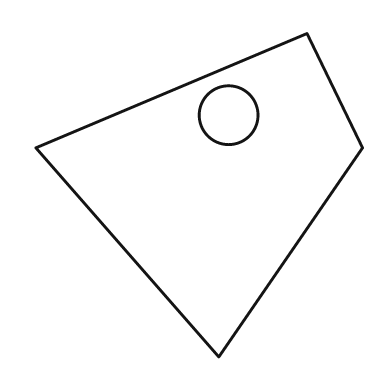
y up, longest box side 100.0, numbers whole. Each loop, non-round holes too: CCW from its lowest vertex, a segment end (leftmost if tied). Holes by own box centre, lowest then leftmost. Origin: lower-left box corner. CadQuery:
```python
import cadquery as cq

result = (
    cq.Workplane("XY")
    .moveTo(56.0, 0.0)
    .lineTo(100.0, 64.0)
    .lineTo(83.0, 99.0)
    .lineTo(0.0, 64.0)
    .close()
    .moveTo(59.0, 74.0)
    .circle(9.0)
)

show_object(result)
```